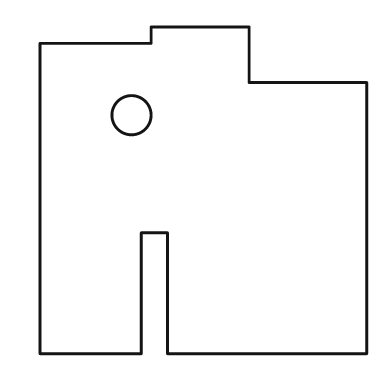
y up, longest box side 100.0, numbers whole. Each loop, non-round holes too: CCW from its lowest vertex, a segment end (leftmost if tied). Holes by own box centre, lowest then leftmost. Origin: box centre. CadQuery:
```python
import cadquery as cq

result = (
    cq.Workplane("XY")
    .moveTo(-50.0, -50.0)
    .lineTo(-19.0, -50.0)
    .lineTo(-19.0, -13.0)
    .lineTo(-11.0, -13.0)
    .lineTo(-11.0, -50.0)
    .lineTo(50.0, -50.0)
    .lineTo(50.0, 33.0)
    .lineTo(14.0, 33.0)
    .lineTo(14.0, 50.0)
    .lineTo(-16.0, 50.0)
    .lineTo(-16.0, 45.0)
    .lineTo(-50.0, 45.0)
    .close()
    .moveTo(-22.0, 23.0)
    .circle(6.0)
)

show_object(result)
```